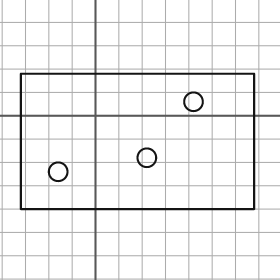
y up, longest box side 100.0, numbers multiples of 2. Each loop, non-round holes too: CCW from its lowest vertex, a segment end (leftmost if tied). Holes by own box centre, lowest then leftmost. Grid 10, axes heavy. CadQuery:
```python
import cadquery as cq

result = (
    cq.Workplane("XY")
    .moveTo(-32.0, -40.0)
    .lineTo(68.0, -40.0)
    .lineTo(68.0, 18.0)
    .lineTo(-32.0, 18.0)
    .close()
    .moveTo(-16.0, -24.0)
    .circle(4.0)
    .moveTo(22.0, -18.0)
    .circle(4.0)
    .moveTo(42.0, 6.0)
    .circle(4.0)
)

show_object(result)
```